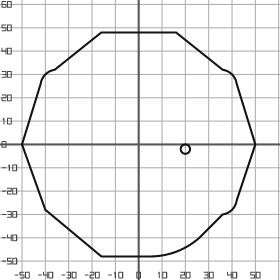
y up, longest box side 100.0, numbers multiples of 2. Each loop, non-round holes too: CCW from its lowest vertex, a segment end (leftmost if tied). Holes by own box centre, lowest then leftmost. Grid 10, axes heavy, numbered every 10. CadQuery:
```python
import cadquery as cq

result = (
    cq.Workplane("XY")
    .moveTo(-16.0, -48.0)
    .lineTo(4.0, -48.0)
    .threePointArc((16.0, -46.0), (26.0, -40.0))
    .lineTo(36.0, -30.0)
    .threePointArc((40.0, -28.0), (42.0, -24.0))
    .lineTo(50.0, 0.0)
    .lineTo(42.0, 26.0)
    .threePointArc((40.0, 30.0), (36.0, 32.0))
    .lineTo(16.0, 48.0)
    .lineTo(-16.0, 48.0)
    .lineTo(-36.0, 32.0)
    .threePointArc((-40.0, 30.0), (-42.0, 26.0))
    .lineTo(-50.0, 0.0)
    .lineTo(-40.0, -28.0)
    .close()
    .moveTo(20.0, -2.0)
    .circle(2.0)
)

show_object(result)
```